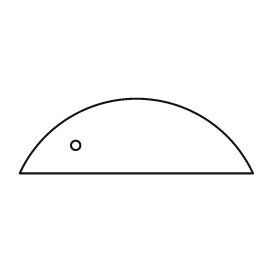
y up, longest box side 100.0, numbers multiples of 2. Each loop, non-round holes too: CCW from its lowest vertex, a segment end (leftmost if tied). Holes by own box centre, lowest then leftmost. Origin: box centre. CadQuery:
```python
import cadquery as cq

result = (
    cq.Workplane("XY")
    .moveTo(-50.0, -16.0)
    .lineTo(50.0, -16.0)
    .threePointArc((0.0, 16.0), (-50.0, -16.0))
    .close()
    .moveTo(-26.0, -4.0)
    .circle(2.0)
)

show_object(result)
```